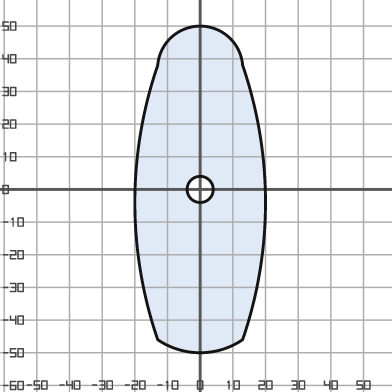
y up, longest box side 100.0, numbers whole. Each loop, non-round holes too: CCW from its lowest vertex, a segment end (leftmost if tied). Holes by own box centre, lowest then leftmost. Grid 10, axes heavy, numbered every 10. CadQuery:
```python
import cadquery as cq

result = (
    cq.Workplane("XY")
    .moveTo(-13.0, -46.0)
    .threePointArc((0.0, -50.0), (13.0, -46.0))
    .threePointArc((20.0, -4.0), (13.0, 38.0))
    .threePointArc((0.0, 50.0), (-13.0, 38.0))
    .threePointArc((-20.0, -4.0), (-13.0, -46.0))
    .close()
    .moveTo(0.0, 0.0)
    .circle(4.0)
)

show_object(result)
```